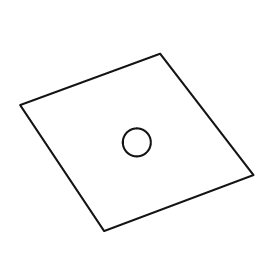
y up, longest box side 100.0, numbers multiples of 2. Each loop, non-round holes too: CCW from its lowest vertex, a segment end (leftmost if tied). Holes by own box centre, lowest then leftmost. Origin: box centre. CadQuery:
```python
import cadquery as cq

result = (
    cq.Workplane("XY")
    .moveTo(-14.0, -38.0)
    .lineTo(50.0, -14.0)
    .lineTo(10.0, 38.0)
    .lineTo(-50.0, 16.0)
    .close()
    .moveTo(0.0, 0.0)
    .circle(6.0)
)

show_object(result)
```